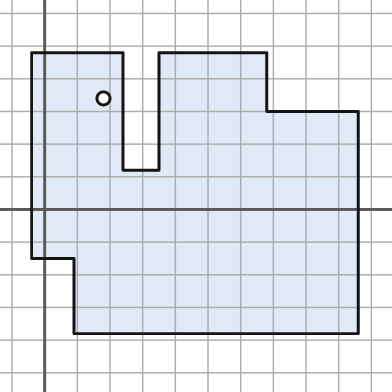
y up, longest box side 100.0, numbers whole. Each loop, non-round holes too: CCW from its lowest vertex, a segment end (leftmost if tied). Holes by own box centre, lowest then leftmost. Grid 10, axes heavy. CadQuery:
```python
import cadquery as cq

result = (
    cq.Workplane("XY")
    .moveTo(9.0, -38.0)
    .lineTo(96.0, -38.0)
    .lineTo(96.0, 30.0)
    .lineTo(68.0, 30.0)
    .lineTo(68.0, 48.0)
    .lineTo(35.0, 48.0)
    .lineTo(35.0, 12.0)
    .lineTo(24.0, 12.0)
    .lineTo(24.0, 48.0)
    .lineTo(-4.0, 48.0)
    .lineTo(-4.0, -15.0)
    .lineTo(9.0, -15.0)
    .close()
    .moveTo(18.0, 34.0)
    .circle(2.0)
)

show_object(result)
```